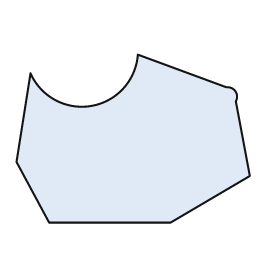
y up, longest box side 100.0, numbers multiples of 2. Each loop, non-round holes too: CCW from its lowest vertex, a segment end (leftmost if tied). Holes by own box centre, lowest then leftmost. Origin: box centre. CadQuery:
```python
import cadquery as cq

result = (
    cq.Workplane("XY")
    .moveTo(-36.0, -36.0)
    .lineTo(16.0, -36.0)
    .lineTo(50.0, -16.0)
    .lineTo(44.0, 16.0)
    .threePointArc((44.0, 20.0), (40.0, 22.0))
    .lineTo(2.0, 36.0)
    .threePointArc((-18.0, 14.0), (-44.0, 28.0))
    .lineTo(-50.0, -10.0)
    .close()
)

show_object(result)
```